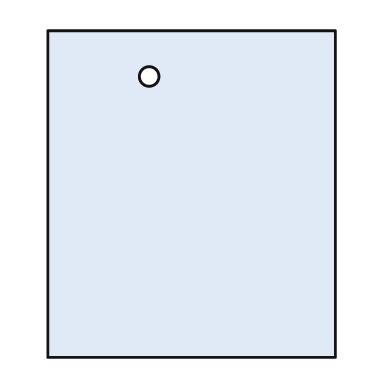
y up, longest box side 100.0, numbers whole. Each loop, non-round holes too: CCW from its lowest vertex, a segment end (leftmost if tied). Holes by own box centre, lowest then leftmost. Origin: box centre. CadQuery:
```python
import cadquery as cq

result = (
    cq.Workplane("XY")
    .moveTo(-44.0, -50.0)
    .lineTo(44.0, -50.0)
    .lineTo(44.0, 50.0)
    .lineTo(-44.0, 50.0)
    .close()
    .moveTo(-13.0, 36.0)
    .circle(3.0)
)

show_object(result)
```